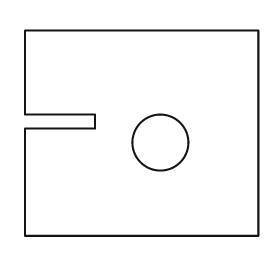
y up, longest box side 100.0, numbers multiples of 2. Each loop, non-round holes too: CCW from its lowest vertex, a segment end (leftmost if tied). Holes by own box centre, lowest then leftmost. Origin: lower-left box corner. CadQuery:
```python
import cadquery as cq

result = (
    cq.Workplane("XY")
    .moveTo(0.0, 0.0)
    .lineTo(100.0, 0.0)
    .lineTo(100.0, 88.0)
    .lineTo(0.0, 88.0)
    .lineTo(0.0, 52.0)
    .lineTo(30.0, 52.0)
    .lineTo(30.0, 46.0)
    .lineTo(0.0, 46.0)
    .close()
    .moveTo(58.0, 40.0)
    .circle(12.0)
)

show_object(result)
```